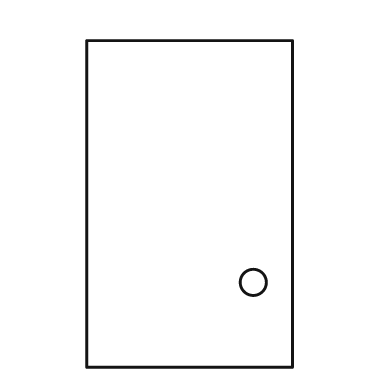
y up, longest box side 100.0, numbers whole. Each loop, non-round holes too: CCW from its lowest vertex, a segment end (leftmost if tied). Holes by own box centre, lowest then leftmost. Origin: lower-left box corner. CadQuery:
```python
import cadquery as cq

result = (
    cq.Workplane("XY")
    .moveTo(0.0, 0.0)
    .lineTo(63.0, 0.0)
    .lineTo(63.0, 100.0)
    .lineTo(0.0, 100.0)
    .close()
    .moveTo(51.0, 26.0)
    .circle(4.0)
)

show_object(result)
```